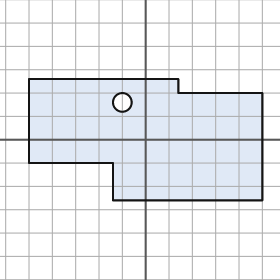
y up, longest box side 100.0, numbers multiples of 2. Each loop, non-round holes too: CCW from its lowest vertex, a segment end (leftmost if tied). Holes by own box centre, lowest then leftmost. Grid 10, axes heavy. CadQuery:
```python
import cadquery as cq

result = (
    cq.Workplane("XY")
    .moveTo(-14.0, -26.0)
    .lineTo(50.0, -26.0)
    .lineTo(50.0, 20.0)
    .lineTo(14.0, 20.0)
    .lineTo(14.0, 26.0)
    .lineTo(-50.0, 26.0)
    .lineTo(-50.0, -10.0)
    .lineTo(-14.0, -10.0)
    .close()
    .moveTo(-10.0, 16.0)
    .circle(4.0)
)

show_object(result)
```